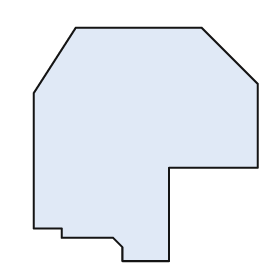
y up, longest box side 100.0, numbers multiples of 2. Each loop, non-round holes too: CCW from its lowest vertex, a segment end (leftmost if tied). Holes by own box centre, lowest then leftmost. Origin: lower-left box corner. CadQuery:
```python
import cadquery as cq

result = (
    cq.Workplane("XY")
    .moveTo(38.0, 0.0)
    .lineTo(58.0, 0.0)
    .lineTo(58.0, 40.0)
    .lineTo(96.0, 40.0)
    .lineTo(96.0, 76.0)
    .lineTo(72.0, 100.0)
    .lineTo(18.0, 100.0)
    .lineTo(0.0, 72.0)
    .lineTo(0.0, 14.0)
    .lineTo(12.0, 14.0)
    .lineTo(12.0, 10.0)
    .lineTo(34.0, 10.0)
    .lineTo(38.0, 6.0)
    .close()
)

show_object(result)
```